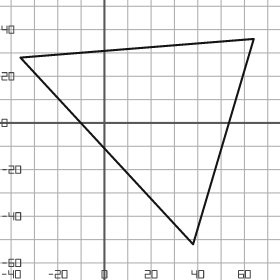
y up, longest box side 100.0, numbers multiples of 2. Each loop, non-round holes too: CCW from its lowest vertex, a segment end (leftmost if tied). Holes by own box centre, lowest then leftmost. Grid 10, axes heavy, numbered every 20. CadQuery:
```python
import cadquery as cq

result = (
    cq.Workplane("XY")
    .moveTo(38.0, -52.0)
    .lineTo(64.0, 36.0)
    .lineTo(-36.0, 28.0)
    .close()
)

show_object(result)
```